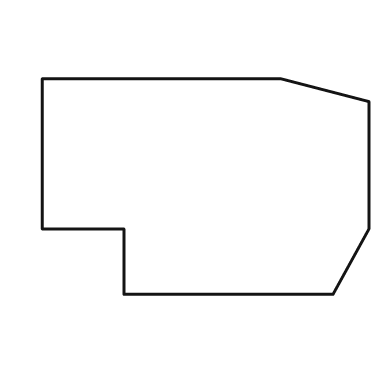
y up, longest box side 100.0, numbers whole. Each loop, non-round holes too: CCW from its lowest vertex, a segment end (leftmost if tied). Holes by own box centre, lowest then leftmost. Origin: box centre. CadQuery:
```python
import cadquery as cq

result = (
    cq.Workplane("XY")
    .moveTo(-25.0, -33.0)
    .lineTo(39.0, -33.0)
    .lineTo(50.0, -13.0)
    .lineTo(50.0, 26.0)
    .lineTo(23.0, 33.0)
    .lineTo(-50.0, 33.0)
    .lineTo(-50.0, -13.0)
    .lineTo(-25.0, -13.0)
    .close()
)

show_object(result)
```